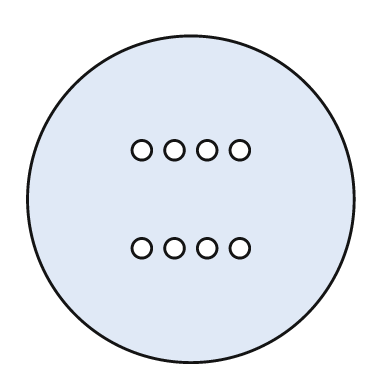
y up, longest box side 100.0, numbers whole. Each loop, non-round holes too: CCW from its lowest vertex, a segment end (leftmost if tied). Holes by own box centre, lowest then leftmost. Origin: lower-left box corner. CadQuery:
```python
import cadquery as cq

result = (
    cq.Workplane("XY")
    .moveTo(50.0, 50.0)
    .circle(50.0)
    .moveTo(35.0, 35.0)
    .circle(3.0)
    .moveTo(45.0, 35.0)
    .circle(3.0)
    .moveTo(55.0, 35.0)
    .circle(3.0)
    .moveTo(65.0, 35.0)
    .circle(3.0)
    .moveTo(35.0, 65.0)
    .circle(3.0)
    .moveTo(45.0, 65.0)
    .circle(3.0)
    .moveTo(55.0, 65.0)
    .circle(3.0)
    .moveTo(65.0, 65.0)
    .circle(3.0)
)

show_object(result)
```